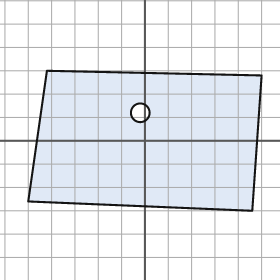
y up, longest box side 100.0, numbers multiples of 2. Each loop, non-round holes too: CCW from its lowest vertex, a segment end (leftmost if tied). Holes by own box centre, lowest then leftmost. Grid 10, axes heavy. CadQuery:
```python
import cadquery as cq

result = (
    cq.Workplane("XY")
    .moveTo(46.0, -30.0)
    .lineTo(50.0, 28.0)
    .lineTo(-42.0, 30.0)
    .lineTo(-50.0, -26.0)
    .close()
    .moveTo(-2.0, 12.0)
    .circle(4.0)
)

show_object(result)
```